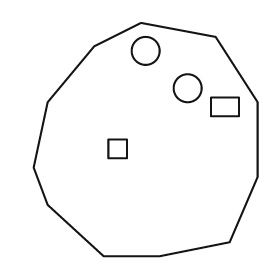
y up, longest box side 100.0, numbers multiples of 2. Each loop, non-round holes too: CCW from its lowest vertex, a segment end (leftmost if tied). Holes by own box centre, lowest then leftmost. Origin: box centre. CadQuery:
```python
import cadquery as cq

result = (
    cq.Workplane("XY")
    .moveTo(-18.0, -50.0)
    .lineTo(6.0, -50.0)
    .lineTo(36.0, -44.0)
    .lineTo(48.0, -16.0)
    .lineTo(48.0, 16.0)
    .lineTo(30.0, 44.0)
    .lineTo(-2.0, 50.0)
    .lineTo(-22.0, 40.0)
    .lineTo(-42.0, 16.0)
    .lineTo(-48.0, -12.0)
    .lineTo(-42.0, -28.0)
    .close()
    .moveTo(-16.0, -8.0)
    .lineTo(-8.0, -8.0)
    .lineTo(-8.0, 0.0)
    .lineTo(-16.0, 0.0)
    .close()
    .moveTo(28.0, 10.0)
    .lineTo(40.0, 10.0)
    .lineTo(40.0, 18.0)
    .lineTo(28.0, 18.0)
    .close()
    .moveTo(18.0, 22.0)
    .circle(6.0)
    .moveTo(0.0, 38.0)
    .circle(6.0)
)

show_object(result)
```